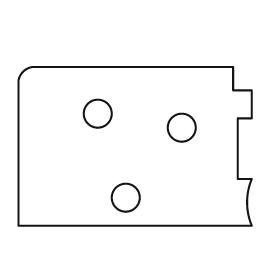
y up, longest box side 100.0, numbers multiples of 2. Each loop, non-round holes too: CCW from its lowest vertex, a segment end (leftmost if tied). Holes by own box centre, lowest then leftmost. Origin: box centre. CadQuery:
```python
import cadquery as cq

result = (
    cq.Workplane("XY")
    .moveTo(-50.0, -34.0)
    .lineTo(50.0, -34.0)
    .threePointArc((48.0, -24.0), (50.0, -14.0))
    .lineTo(44.0, -14.0)
    .lineTo(44.0, 12.0)
    .lineTo(50.0, 12.0)
    .lineTo(50.0, 24.0)
    .lineTo(42.0, 24.0)
    .lineTo(42.0, 34.0)
    .lineTo(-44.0, 34.0)
    .threePointArc((-48.0, 32.0), (-50.0, 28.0))
    .close()
    .moveTo(-4.0, -22.0)
    .circle(6.0)
    .moveTo(20.0, 8.0)
    .circle(6.0)
    .moveTo(-16.0, 14.0)
    .circle(6.0)
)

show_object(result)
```